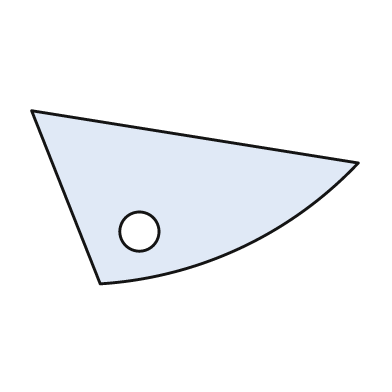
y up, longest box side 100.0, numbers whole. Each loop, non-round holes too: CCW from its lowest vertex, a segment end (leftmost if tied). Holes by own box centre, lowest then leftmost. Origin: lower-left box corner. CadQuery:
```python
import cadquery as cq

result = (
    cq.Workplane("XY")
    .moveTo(21.0, 0.0)
    .threePointArc((64.0, 11.0), (100.0, 37.0))
    .lineTo(0.0, 53.0)
    .close()
    .moveTo(33.0, 16.0)
    .circle(6.0)
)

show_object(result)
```